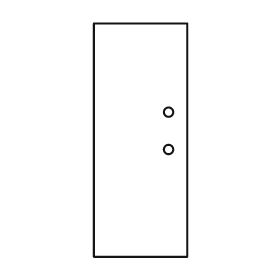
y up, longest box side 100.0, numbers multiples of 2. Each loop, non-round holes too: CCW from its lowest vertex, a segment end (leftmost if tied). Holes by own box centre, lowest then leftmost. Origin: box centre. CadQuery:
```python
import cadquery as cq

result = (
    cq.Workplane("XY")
    .moveTo(-20.0, -50.0)
    .lineTo(20.0, -50.0)
    .lineTo(20.0, 50.0)
    .lineTo(-20.0, 50.0)
    .close()
    .moveTo(12.0, -4.0)
    .circle(2.0)
    .moveTo(12.0, 12.0)
    .circle(2.0)
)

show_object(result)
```